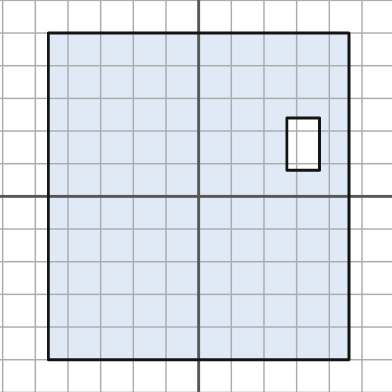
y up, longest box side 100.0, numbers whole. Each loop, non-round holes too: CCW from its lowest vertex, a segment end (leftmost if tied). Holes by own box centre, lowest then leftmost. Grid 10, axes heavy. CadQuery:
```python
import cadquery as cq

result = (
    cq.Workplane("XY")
    .moveTo(-46.0, -50.0)
    .lineTo(46.0, -50.0)
    .lineTo(46.0, 50.0)
    .lineTo(-46.0, 50.0)
    .close()
    .moveTo(27.0, 8.0)
    .lineTo(37.0, 8.0)
    .lineTo(37.0, 24.0)
    .lineTo(27.0, 24.0)
    .close()
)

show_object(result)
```